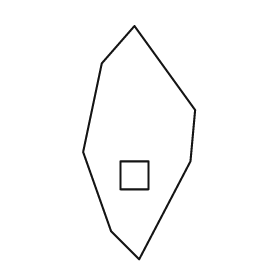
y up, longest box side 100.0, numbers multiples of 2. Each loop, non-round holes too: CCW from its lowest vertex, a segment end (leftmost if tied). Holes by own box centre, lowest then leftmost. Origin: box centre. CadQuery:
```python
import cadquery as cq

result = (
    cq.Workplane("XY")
    .moveTo(0.0, -50.0)
    .lineTo(22.0, -8.0)
    .lineTo(24.0, 14.0)
    .lineTo(-2.0, 50.0)
    .lineTo(-16.0, 34.0)
    .lineTo(-24.0, -4.0)
    .lineTo(-12.0, -38.0)
    .close()
    .moveTo(-8.0, -20.0)
    .lineTo(4.0, -20.0)
    .lineTo(4.0, -8.0)
    .lineTo(-8.0, -8.0)
    .close()
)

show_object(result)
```